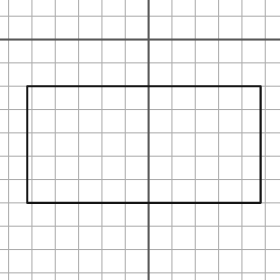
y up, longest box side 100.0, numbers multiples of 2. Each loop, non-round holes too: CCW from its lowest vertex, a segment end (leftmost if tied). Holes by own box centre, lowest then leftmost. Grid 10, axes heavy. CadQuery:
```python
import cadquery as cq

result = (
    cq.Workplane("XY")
    .moveTo(-52.0, -70.0)
    .lineTo(48.0, -70.0)
    .lineTo(48.0, -20.0)
    .lineTo(-52.0, -20.0)
    .close()
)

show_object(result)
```